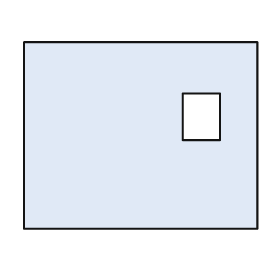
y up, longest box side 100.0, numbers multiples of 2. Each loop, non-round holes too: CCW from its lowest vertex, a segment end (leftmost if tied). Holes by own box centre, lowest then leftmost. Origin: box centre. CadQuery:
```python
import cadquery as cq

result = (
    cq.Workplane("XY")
    .moveTo(-50.0, -40.0)
    .lineTo(50.0, -40.0)
    .lineTo(50.0, 40.0)
    .lineTo(-50.0, 40.0)
    .close()
    .moveTo(18.0, -2.0)
    .lineTo(34.0, -2.0)
    .lineTo(34.0, 18.0)
    .lineTo(18.0, 18.0)
    .close()
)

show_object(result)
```